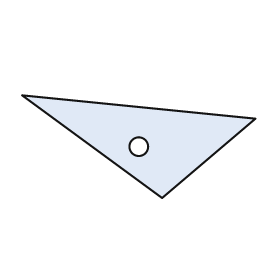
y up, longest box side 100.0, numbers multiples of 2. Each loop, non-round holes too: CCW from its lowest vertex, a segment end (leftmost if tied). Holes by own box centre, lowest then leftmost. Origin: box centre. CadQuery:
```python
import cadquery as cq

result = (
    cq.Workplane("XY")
    .moveTo(10.0, -22.0)
    .lineTo(50.0, 12.0)
    .lineTo(-50.0, 22.0)
    .close()
    .moveTo(0.0, 0.0)
    .circle(4.0)
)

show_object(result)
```